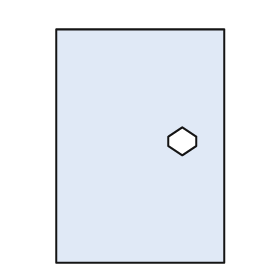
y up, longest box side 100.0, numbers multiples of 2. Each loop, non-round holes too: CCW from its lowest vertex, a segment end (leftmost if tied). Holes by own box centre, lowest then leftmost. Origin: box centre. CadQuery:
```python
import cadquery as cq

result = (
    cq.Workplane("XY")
    .moveTo(-36.0, -50.0)
    .lineTo(36.0, -50.0)
    .lineTo(36.0, 50.0)
    .lineTo(-36.0, 50.0)
    .close()
    .moveTo(18.0, -4.0)
    .lineTo(24.0, 0.0)
    .lineTo(24.0, 4.0)
    .lineTo(18.0, 8.0)
    .lineTo(12.0, 4.0)
    .lineTo(12.0, 0.0)
    .close()
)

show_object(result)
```